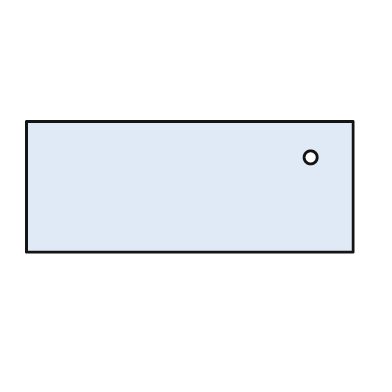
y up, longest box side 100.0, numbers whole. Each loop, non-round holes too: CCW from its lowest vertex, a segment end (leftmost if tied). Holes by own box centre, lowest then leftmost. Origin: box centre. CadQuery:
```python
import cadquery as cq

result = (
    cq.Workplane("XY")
    .moveTo(-50.0, -20.0)
    .lineTo(50.0, -20.0)
    .lineTo(50.0, 20.0)
    .lineTo(-50.0, 20.0)
    .close()
    .moveTo(37.0, 9.0)
    .circle(2.0)
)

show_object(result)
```